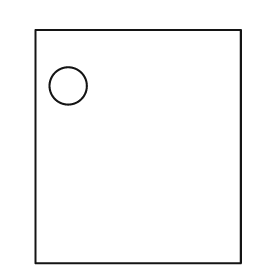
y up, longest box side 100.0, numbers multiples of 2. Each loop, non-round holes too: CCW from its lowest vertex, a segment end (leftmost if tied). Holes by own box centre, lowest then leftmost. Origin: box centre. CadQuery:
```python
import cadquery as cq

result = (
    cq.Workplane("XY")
    .moveTo(-44.0, -50.0)
    .lineTo(44.0, -50.0)
    .lineTo(44.0, 50.0)
    .lineTo(-44.0, 50.0)
    .close()
    .moveTo(-30.0, 26.0)
    .circle(8.0)
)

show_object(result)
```